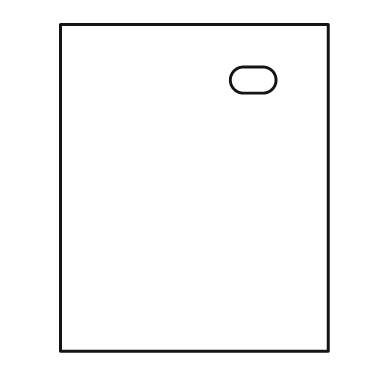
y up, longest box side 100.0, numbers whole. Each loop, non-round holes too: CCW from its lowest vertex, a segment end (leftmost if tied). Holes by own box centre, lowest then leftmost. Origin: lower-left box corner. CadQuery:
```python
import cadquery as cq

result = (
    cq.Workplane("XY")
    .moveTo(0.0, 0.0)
    .lineTo(82.0, 0.0)
    .lineTo(82.0, 100.0)
    .lineTo(0.0, 100.0)
    .close()
    .moveTo(56.0, 79.0)
    .lineTo(62.0, 79.0)
    .threePointArc((66.0, 83.0), (62.0, 87.0))
    .lineTo(56.0, 87.0)
    .threePointArc((52.0, 83.0), (56.0, 79.0))
    .close()
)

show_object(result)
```